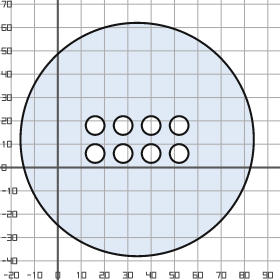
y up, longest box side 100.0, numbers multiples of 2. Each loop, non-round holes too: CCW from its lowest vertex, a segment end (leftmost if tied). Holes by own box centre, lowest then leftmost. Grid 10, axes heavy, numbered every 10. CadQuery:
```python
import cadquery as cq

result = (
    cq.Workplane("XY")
    .moveTo(34.0, 12.0)
    .circle(50.0)
    .moveTo(16.0, 6.0)
    .circle(4.0)
    .moveTo(28.0, 6.0)
    .circle(4.0)
    .moveTo(40.0, 6.0)
    .circle(4.0)
    .moveTo(52.0, 6.0)
    .circle(4.0)
    .moveTo(16.0, 18.0)
    .circle(4.0)
    .moveTo(28.0, 18.0)
    .circle(4.0)
    .moveTo(40.0, 18.0)
    .circle(4.0)
    .moveTo(52.0, 18.0)
    .circle(4.0)
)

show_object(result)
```